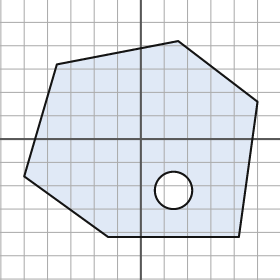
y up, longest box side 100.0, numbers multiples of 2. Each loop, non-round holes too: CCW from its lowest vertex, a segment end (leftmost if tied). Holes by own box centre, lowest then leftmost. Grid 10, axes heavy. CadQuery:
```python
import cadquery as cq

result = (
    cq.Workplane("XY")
    .moveTo(-14.0, -42.0)
    .lineTo(42.0, -42.0)
    .lineTo(50.0, 16.0)
    .lineTo(16.0, 42.0)
    .lineTo(-36.0, 32.0)
    .lineTo(-50.0, -16.0)
    .close()
    .moveTo(14.0, -22.0)
    .circle(8.0)
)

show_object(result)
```